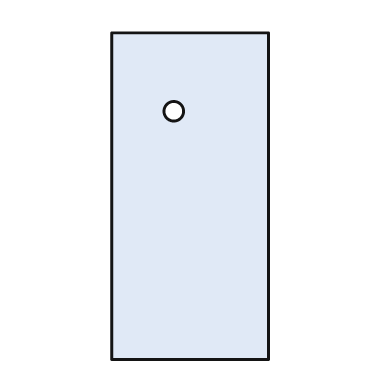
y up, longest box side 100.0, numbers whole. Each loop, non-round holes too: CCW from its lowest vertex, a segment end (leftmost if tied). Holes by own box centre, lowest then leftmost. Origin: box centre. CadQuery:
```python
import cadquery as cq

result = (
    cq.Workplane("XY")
    .moveTo(-24.0, -50.0)
    .lineTo(24.0, -50.0)
    .lineTo(24.0, 50.0)
    .lineTo(-24.0, 50.0)
    .close()
    .moveTo(-5.0, 26.0)
    .circle(3.0)
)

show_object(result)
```